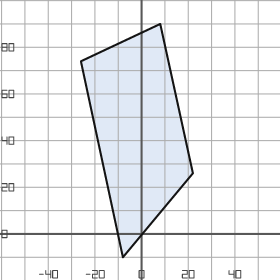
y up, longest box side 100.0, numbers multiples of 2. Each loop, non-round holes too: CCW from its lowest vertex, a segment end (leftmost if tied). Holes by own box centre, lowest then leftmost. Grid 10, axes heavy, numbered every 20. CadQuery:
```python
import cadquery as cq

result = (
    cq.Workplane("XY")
    .moveTo(-8.0, -10.0)
    .lineTo(22.0, 26.0)
    .lineTo(8.0, 90.0)
    .lineTo(-26.0, 74.0)
    .close()
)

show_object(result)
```